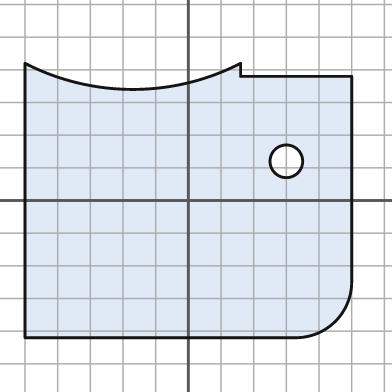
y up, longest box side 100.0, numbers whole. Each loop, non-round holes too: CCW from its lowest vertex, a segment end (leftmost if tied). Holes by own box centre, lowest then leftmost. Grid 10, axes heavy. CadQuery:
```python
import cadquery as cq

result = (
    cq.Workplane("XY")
    .moveTo(-50.0, -42.0)
    .lineTo(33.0, -42.0)
    .threePointArc((45.0, -37.0), (50.0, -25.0))
    .lineTo(50.0, 38.0)
    .lineTo(16.0, 38.0)
    .lineTo(16.0, 42.0)
    .threePointArc((-17.0, 34.0), (-50.0, 42.0))
    .close()
    .moveTo(30.0, 12.0)
    .circle(5.0)
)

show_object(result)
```